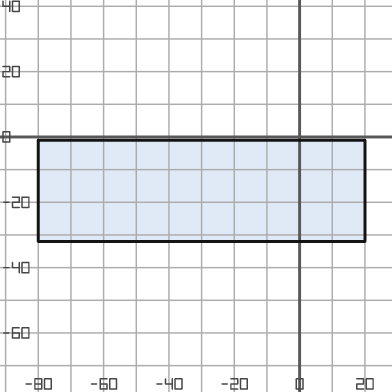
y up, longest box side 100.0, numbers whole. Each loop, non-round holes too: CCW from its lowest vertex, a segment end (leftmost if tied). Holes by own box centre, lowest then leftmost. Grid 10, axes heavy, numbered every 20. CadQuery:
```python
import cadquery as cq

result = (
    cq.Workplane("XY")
    .moveTo(-80.0, -32.0)
    .lineTo(20.0, -32.0)
    .lineTo(20.0, -1.0)
    .lineTo(-80.0, -1.0)
    .close()
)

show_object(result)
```